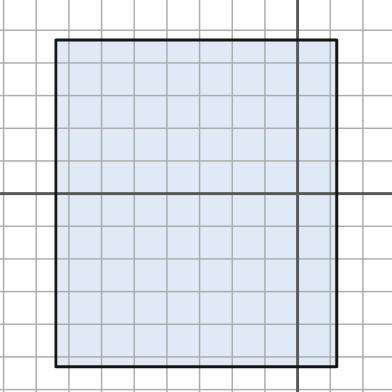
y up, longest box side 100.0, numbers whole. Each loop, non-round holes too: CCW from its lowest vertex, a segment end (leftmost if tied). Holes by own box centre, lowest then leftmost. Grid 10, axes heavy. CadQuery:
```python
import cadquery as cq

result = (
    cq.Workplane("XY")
    .moveTo(-74.0, -53.0)
    .lineTo(12.0, -53.0)
    .lineTo(12.0, 47.0)
    .lineTo(-74.0, 47.0)
    .close()
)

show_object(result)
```